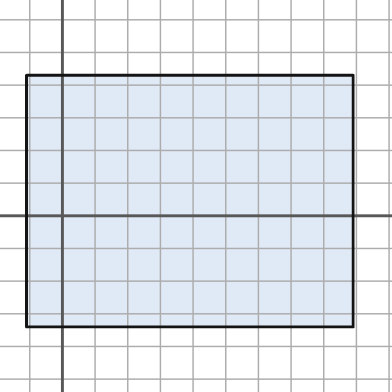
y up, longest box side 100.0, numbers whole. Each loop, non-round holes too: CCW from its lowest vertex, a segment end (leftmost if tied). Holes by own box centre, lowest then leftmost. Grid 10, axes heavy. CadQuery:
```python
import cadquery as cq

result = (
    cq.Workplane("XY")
    .moveTo(-11.0, -34.0)
    .lineTo(89.0, -34.0)
    .lineTo(89.0, 43.0)
    .lineTo(-11.0, 43.0)
    .close()
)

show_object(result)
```